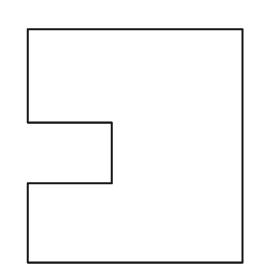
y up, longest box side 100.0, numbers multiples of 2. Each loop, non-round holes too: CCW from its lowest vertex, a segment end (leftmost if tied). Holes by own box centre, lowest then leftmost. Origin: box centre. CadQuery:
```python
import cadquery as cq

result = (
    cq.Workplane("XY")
    .moveTo(-46.0, -50.0)
    .lineTo(46.0, -50.0)
    .lineTo(46.0, 50.0)
    .lineTo(-46.0, 50.0)
    .lineTo(-46.0, 10.0)
    .lineTo(-10.0, 10.0)
    .lineTo(-10.0, -16.0)
    .lineTo(-46.0, -16.0)
    .close()
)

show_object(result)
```